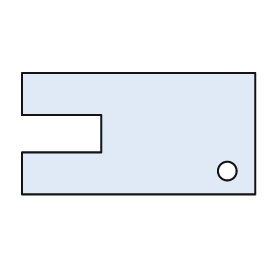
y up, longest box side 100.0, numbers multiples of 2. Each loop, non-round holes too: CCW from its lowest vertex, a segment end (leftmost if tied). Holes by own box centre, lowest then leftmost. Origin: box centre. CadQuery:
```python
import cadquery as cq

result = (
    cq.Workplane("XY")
    .moveTo(-50.0, -26.0)
    .lineTo(50.0, -26.0)
    .lineTo(50.0, 26.0)
    .lineTo(-50.0, 26.0)
    .lineTo(-50.0, 8.0)
    .lineTo(-16.0, 8.0)
    .lineTo(-16.0, -8.0)
    .lineTo(-50.0, -8.0)
    .close()
    .moveTo(38.0, -16.0)
    .circle(4.0)
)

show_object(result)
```